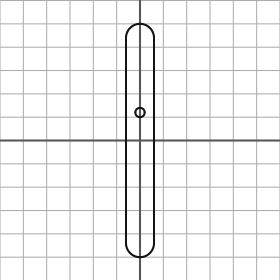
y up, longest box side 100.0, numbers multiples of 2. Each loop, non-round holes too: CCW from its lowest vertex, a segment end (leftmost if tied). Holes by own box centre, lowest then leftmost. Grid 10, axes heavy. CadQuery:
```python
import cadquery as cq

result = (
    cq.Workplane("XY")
    .moveTo(-6.0, -44.0)
    .threePointArc((0.0, -50.0), (6.0, -44.0))
    .lineTo(6.0, 44.0)
    .threePointArc((0.0, 50.0), (-6.0, 44.0))
    .close()
    .moveTo(0.0, 12.0)
    .circle(2.0)
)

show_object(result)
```